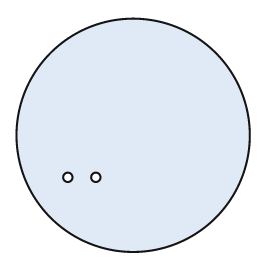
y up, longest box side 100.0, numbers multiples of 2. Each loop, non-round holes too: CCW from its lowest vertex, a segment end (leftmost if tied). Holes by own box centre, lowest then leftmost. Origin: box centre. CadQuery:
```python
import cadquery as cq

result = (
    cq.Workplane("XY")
    .moveTo(0.0, 0.0)
    .circle(50.0)
    .moveTo(-28.0, -18.0)
    .circle(2.0)
    .moveTo(-16.0, -18.0)
    .circle(2.0)
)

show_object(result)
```